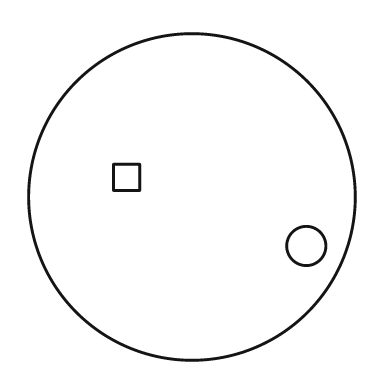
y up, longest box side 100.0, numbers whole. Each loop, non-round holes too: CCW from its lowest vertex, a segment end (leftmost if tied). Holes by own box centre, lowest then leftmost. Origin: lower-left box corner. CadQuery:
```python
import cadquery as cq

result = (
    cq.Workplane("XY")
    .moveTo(50.0, 50.0)
    .circle(50.0)
    .moveTo(85.0, 35.0)
    .circle(6.0)
    .moveTo(26.0, 52.0)
    .lineTo(34.0, 52.0)
    .lineTo(34.0, 60.0)
    .lineTo(26.0, 60.0)
    .close()
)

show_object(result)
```